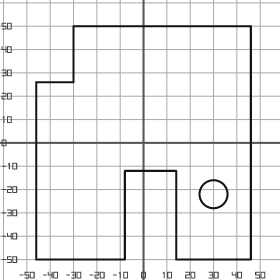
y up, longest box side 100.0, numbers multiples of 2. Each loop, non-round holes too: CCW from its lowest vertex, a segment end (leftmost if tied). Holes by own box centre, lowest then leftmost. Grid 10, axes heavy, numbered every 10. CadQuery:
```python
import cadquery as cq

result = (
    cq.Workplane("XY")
    .moveTo(-46.0, -50.0)
    .lineTo(-8.0, -50.0)
    .lineTo(-8.0, -12.0)
    .lineTo(14.0, -12.0)
    .lineTo(14.0, -50.0)
    .lineTo(46.0, -50.0)
    .lineTo(46.0, 50.0)
    .lineTo(-30.0, 50.0)
    .lineTo(-30.0, 26.0)
    .lineTo(-46.0, 26.0)
    .close()
    .moveTo(30.0, -22.0)
    .circle(6.0)
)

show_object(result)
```